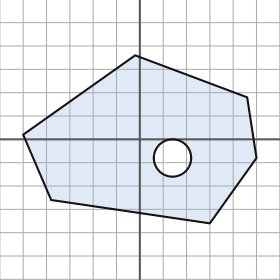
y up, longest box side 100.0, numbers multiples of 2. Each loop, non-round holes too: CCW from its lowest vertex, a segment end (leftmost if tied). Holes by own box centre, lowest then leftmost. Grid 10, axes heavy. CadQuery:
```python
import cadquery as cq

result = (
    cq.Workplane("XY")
    .moveTo(30.0, -36.0)
    .lineTo(50.0, -8.0)
    .lineTo(46.0, 18.0)
    .lineTo(-2.0, 36.0)
    .lineTo(-50.0, 2.0)
    .lineTo(-38.0, -26.0)
    .close()
    .moveTo(14.0, -8.0)
    .circle(8.0)
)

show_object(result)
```